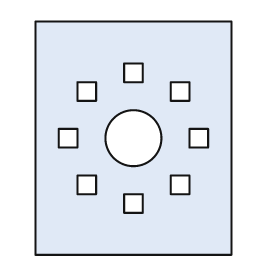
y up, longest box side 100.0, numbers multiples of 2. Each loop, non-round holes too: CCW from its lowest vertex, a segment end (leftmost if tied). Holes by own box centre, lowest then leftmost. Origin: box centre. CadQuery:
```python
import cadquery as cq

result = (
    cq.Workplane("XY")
    .moveTo(-42.0, -50.0)
    .lineTo(42.0, -50.0)
    .lineTo(42.0, 50.0)
    .lineTo(-42.0, 50.0)
    .close()
    .moveTo(-4.0, -32.0)
    .lineTo(4.0, -32.0)
    .lineTo(4.0, -24.0)
    .lineTo(-4.0, -24.0)
    .close()
    .moveTo(-24.0, -24.0)
    .lineTo(-16.0, -24.0)
    .lineTo(-16.0, -16.0)
    .lineTo(-24.0, -16.0)
    .close()
    .moveTo(16.0, -24.0)
    .lineTo(24.0, -24.0)
    .lineTo(24.0, -16.0)
    .lineTo(16.0, -16.0)
    .close()
    .moveTo(-32.0, -4.0)
    .lineTo(-24.0, -4.0)
    .lineTo(-24.0, 4.0)
    .lineTo(-32.0, 4.0)
    .close()
    .moveTo(0.0, 0.0)
    .circle(12.0)
    .moveTo(24.0, -4.0)
    .lineTo(32.0, -4.0)
    .lineTo(32.0, 4.0)
    .lineTo(24.0, 4.0)
    .close()
    .moveTo(-24.0, 16.0)
    .lineTo(-16.0, 16.0)
    .lineTo(-16.0, 24.0)
    .lineTo(-24.0, 24.0)
    .close()
    .moveTo(16.0, 16.0)
    .lineTo(24.0, 16.0)
    .lineTo(24.0, 24.0)
    .lineTo(16.0, 24.0)
    .close()
    .moveTo(-4.0, 24.0)
    .lineTo(4.0, 24.0)
    .lineTo(4.0, 32.0)
    .lineTo(-4.0, 32.0)
    .close()
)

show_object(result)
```